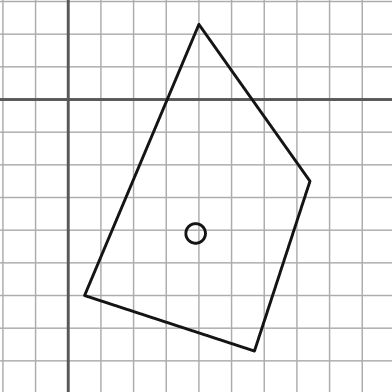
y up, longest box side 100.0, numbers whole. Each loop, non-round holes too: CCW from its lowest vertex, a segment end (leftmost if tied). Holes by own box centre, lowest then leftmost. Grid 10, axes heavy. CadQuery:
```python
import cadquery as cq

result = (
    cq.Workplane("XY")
    .moveTo(57.0, -77.0)
    .lineTo(74.0, -25.0)
    .lineTo(40.0, 23.0)
    .lineTo(5.0, -60.0)
    .close()
    .moveTo(39.0, -41.0)
    .circle(3.0)
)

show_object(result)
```